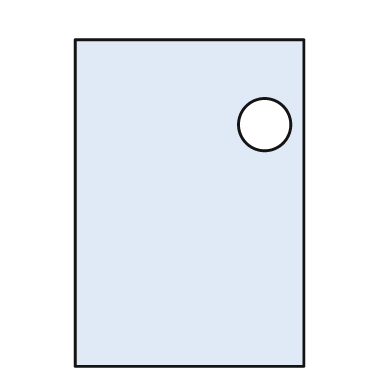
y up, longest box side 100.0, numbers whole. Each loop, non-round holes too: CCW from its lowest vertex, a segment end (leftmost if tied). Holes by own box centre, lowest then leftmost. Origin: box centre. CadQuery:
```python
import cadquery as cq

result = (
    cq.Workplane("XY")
    .moveTo(-35.0, -50.0)
    .lineTo(35.0, -50.0)
    .lineTo(35.0, 50.0)
    .lineTo(-35.0, 50.0)
    .close()
    .moveTo(23.0, 24.0)
    .circle(8.0)
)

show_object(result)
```